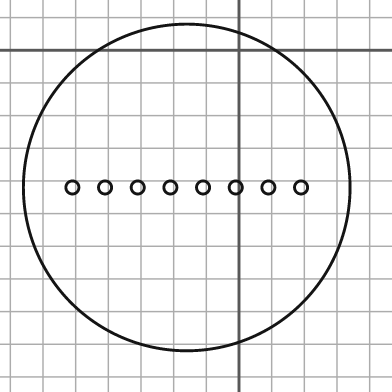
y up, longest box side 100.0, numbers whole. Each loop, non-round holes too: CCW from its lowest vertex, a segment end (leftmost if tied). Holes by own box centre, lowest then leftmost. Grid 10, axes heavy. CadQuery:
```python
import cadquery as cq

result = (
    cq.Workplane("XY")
    .moveTo(-16.0, -42.0)
    .circle(50.0)
    .moveTo(-51.0, -42.0)
    .circle(2.0)
    .moveTo(-41.0, -42.0)
    .circle(2.0)
    .moveTo(-31.0, -42.0)
    .circle(2.0)
    .moveTo(-21.0, -42.0)
    .circle(2.0)
    .moveTo(-11.0, -42.0)
    .circle(2.0)
    .moveTo(-1.0, -42.0)
    .circle(2.0)
    .moveTo(9.0, -42.0)
    .circle(2.0)
    .moveTo(19.0, -42.0)
    .circle(2.0)
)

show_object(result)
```